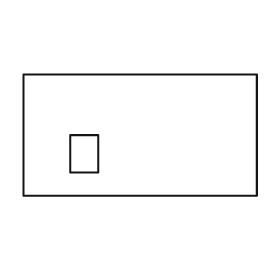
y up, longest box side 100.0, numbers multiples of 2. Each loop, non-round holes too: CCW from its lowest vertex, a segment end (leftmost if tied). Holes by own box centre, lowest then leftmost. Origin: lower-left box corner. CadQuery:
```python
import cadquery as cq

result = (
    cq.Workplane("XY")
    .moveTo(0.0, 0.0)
    .lineTo(100.0, 0.0)
    .lineTo(100.0, 52.0)
    .lineTo(0.0, 52.0)
    .close()
    .moveTo(20.0, 10.0)
    .lineTo(32.0, 10.0)
    .lineTo(32.0, 26.0)
    .lineTo(20.0, 26.0)
    .close()
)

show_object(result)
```